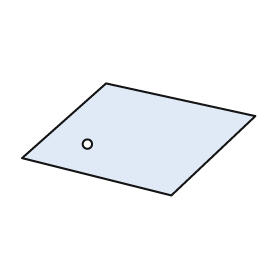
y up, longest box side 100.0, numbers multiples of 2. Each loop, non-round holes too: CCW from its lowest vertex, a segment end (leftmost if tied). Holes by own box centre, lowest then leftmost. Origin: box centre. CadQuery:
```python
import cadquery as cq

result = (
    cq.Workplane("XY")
    .moveTo(14.0, -24.0)
    .lineTo(50.0, 10.0)
    .lineTo(-14.0, 24.0)
    .lineTo(-50.0, -8.0)
    .close()
    .moveTo(-22.0, -2.0)
    .circle(2.0)
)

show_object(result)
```